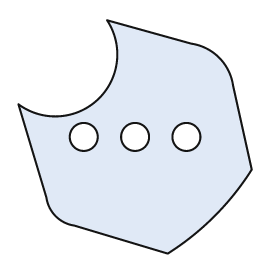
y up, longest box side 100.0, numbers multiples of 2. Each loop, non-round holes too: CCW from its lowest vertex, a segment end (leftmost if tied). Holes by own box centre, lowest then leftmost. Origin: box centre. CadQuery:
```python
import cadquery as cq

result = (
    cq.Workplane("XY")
    .moveTo(14.0, -50.0)
    .threePointArc((34.0, -34.0), (50.0, -14.0))
    .lineTo(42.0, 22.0)
    .threePointArc((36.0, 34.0), (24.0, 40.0))
    .lineTo(-12.0, 50.0)
    .threePointArc((-16.0, 16.0), (-50.0, 14.0))
    .lineTo(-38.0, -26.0)
    .threePointArc((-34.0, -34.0), (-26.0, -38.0))
    .close()
    .moveTo(-22.0, 0.0)
    .circle(6.0)
    .moveTo(0.0, 0.0)
    .circle(6.0)
    .moveTo(22.0, 0.0)
    .circle(6.0)
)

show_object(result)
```